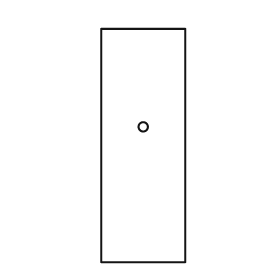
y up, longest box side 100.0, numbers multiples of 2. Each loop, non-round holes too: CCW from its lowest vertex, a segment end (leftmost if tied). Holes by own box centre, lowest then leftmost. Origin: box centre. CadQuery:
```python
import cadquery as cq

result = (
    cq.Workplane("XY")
    .moveTo(-18.0, -50.0)
    .lineTo(18.0, -50.0)
    .lineTo(18.0, 50.0)
    .lineTo(-18.0, 50.0)
    .close()
    .moveTo(0.0, 8.0)
    .circle(2.0)
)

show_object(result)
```